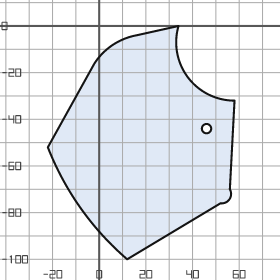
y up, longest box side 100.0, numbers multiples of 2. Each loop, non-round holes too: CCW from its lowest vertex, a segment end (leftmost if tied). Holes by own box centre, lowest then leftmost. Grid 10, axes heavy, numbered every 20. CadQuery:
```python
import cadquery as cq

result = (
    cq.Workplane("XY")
    .moveTo(12.0, -100.0)
    .lineTo(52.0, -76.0)
    .threePointArc((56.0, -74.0), (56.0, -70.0))
    .lineTo(58.0, -32.0)
    .threePointArc((38.0, -22.0), (34.0, 0.0))
    .lineTo(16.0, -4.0)
    .threePointArc((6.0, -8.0), (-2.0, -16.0))
    .lineTo(-22.0, -52.0)
    .threePointArc((-8.0, -78.0), (12.0, -100.0))
    .close()
    .moveTo(46.0, -44.0)
    .circle(2.0)
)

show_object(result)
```